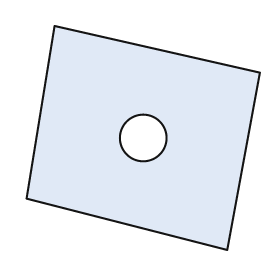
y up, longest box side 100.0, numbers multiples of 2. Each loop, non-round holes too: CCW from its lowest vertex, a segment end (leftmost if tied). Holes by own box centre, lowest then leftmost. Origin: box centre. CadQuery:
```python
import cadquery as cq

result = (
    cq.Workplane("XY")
    .moveTo(36.0, -48.0)
    .lineTo(50.0, 28.0)
    .lineTo(-38.0, 48.0)
    .lineTo(-50.0, -26.0)
    .close()
    .moveTo(0.0, 0.0)
    .circle(10.0)
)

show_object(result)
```